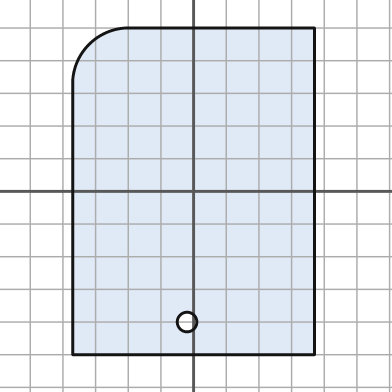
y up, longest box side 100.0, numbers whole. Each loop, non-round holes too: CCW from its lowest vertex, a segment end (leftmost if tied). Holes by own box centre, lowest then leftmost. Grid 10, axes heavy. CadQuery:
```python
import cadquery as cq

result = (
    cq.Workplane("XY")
    .moveTo(-37.0, -50.0)
    .lineTo(37.0, -50.0)
    .lineTo(37.0, 50.0)
    .lineTo(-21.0, 50.0)
    .threePointArc((-32.0, 45.0), (-37.0, 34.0))
    .close()
    .moveTo(-2.0, -40.0)
    .circle(3.0)
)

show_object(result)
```